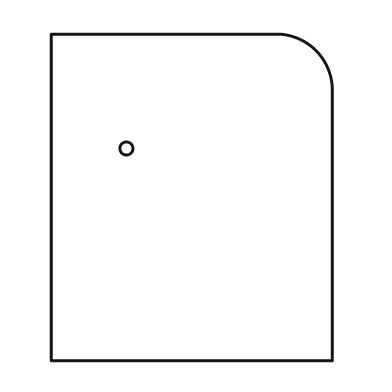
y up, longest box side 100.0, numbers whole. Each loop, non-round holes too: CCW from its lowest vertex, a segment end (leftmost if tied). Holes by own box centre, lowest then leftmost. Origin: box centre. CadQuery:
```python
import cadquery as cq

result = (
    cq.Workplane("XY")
    .moveTo(-43.0, -50.0)
    .lineTo(43.0, -50.0)
    .lineTo(43.0, 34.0)
    .threePointArc((38.0, 45.0), (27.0, 50.0))
    .lineTo(-43.0, 50.0)
    .close()
    .moveTo(-20.0, 15.0)
    .circle(2.0)
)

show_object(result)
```